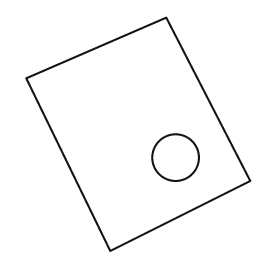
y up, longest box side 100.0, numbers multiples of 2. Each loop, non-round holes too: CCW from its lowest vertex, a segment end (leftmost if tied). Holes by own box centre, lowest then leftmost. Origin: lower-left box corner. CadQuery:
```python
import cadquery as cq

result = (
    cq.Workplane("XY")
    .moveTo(36.0, 0.0)
    .lineTo(96.0, 30.0)
    .lineTo(60.0, 100.0)
    .lineTo(0.0, 74.0)
    .close()
    .moveTo(64.0, 40.0)
    .circle(10.0)
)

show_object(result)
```